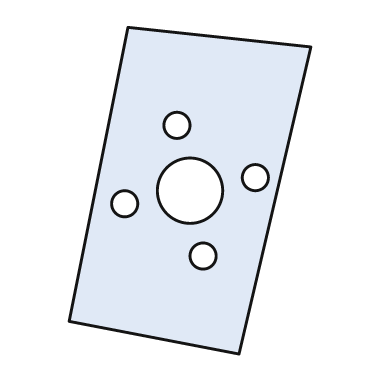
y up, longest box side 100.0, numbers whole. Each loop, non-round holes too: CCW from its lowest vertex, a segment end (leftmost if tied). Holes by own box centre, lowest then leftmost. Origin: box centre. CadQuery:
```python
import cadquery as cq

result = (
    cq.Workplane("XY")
    .moveTo(15.0, -50.0)
    .lineTo(37.0, 44.0)
    .lineTo(-19.0, 50.0)
    .lineTo(-37.0, -40.0)
    .close()
    .moveTo(4.0, -20.0)
    .circle(4.0)
    .moveTo(-20.0, -4.0)
    .circle(4.0)
    .moveTo(0.0, 0.0)
    .circle(10.0)
    .moveTo(20.0, 4.0)
    .circle(4.0)
    .moveTo(-4.0, 20.0)
    .circle(4.0)
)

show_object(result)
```